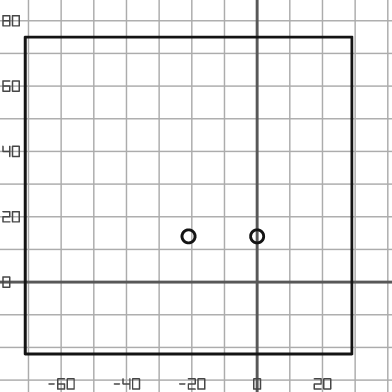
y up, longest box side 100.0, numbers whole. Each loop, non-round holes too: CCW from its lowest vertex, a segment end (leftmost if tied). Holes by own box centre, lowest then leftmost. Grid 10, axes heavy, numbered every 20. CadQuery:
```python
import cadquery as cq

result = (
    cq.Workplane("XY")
    .moveTo(-71.0, -22.0)
    .lineTo(29.0, -22.0)
    .lineTo(29.0, 75.0)
    .lineTo(-71.0, 75.0)
    .close()
    .moveTo(-21.0, 14.0)
    .circle(2.0)
    .moveTo(0.0, 14.0)
    .circle(2.0)
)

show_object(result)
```